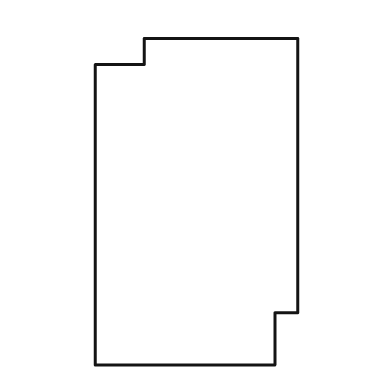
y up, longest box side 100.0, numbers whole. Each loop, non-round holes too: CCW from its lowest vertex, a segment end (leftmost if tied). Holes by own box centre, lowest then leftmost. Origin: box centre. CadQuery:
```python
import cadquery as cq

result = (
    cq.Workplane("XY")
    .moveTo(-31.0, -50.0)
    .lineTo(24.0, -50.0)
    .lineTo(24.0, -34.0)
    .lineTo(31.0, -34.0)
    .lineTo(31.0, 50.0)
    .lineTo(-16.0, 50.0)
    .lineTo(-16.0, 42.0)
    .lineTo(-31.0, 42.0)
    .close()
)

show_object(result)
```